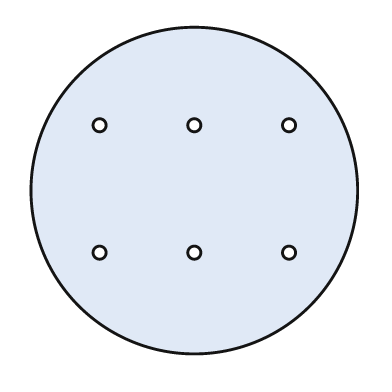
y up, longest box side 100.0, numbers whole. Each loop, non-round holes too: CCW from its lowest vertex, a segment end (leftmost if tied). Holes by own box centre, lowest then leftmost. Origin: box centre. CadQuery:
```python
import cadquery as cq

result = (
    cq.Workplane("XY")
    .moveTo(0.0, 0.0)
    .circle(50.0)
    .moveTo(-29.0, -19.0)
    .circle(2.0)
    .moveTo(0.0, -19.0)
    .circle(2.0)
    .moveTo(29.0, -19.0)
    .circle(2.0)
    .moveTo(-29.0, 20.0)
    .circle(2.0)
    .moveTo(0.0, 20.0)
    .circle(2.0)
    .moveTo(29.0, 20.0)
    .circle(2.0)
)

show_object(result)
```